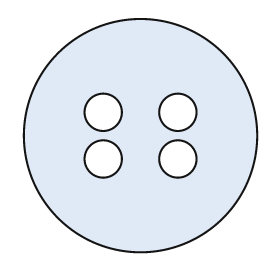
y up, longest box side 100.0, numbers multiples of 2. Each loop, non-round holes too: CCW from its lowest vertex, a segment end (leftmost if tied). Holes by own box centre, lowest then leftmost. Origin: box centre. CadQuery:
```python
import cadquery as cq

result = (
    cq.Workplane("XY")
    .moveTo(0.0, 0.0)
    .circle(50.0)
    .moveTo(-16.0, -10.0)
    .circle(8.0)
    .moveTo(16.0, -10.0)
    .circle(8.0)
    .moveTo(-16.0, 10.0)
    .circle(8.0)
    .moveTo(16.0, 10.0)
    .circle(8.0)
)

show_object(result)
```